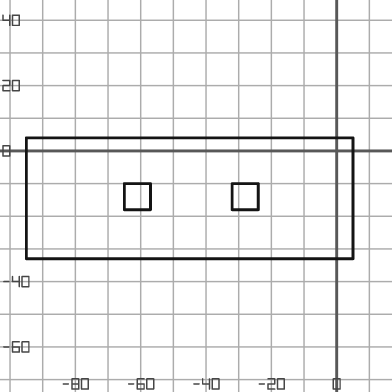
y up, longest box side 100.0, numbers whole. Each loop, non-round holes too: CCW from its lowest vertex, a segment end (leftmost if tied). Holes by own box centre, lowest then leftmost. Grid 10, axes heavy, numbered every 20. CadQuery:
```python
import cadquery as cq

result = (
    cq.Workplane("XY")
    .moveTo(-95.0, -33.0)
    .lineTo(5.0, -33.0)
    .lineTo(5.0, 4.0)
    .lineTo(-95.0, 4.0)
    .close()
    .moveTo(-65.0, -18.0)
    .lineTo(-57.0, -18.0)
    .lineTo(-57.0, -10.0)
    .lineTo(-65.0, -10.0)
    .close()
    .moveTo(-32.0, -18.0)
    .lineTo(-24.0, -18.0)
    .lineTo(-24.0, -10.0)
    .lineTo(-32.0, -10.0)
    .close()
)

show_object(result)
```